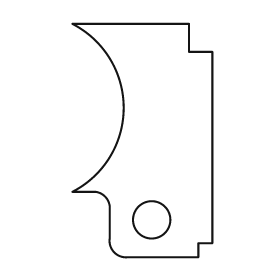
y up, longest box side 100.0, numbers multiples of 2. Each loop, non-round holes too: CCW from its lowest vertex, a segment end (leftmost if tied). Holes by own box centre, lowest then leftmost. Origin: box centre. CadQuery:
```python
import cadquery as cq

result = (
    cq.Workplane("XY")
    .moveTo(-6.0, -50.0)
    .lineTo(24.0, -50.0)
    .lineTo(24.0, -44.0)
    .lineTo(30.0, -44.0)
    .lineTo(30.0, 38.0)
    .lineTo(20.0, 38.0)
    .lineTo(20.0, 50.0)
    .lineTo(-30.0, 50.0)
    .threePointArc((-8.0, 14.0), (-30.0, -22.0))
    .lineTo(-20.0, -22.0)
    .threePointArc((-16.0, -24.0), (-14.0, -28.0))
    .lineTo(-14.0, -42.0)
    .threePointArc((-12.0, -48.0), (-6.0, -50.0))
    .close()
    .moveTo(4.0, -34.0)
    .circle(8.0)
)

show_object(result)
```